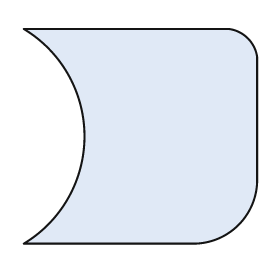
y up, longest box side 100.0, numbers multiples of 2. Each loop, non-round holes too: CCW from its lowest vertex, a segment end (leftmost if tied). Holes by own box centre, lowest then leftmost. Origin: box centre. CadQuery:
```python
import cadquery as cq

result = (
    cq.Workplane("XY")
    .moveTo(-50.0, -46.0)
    .lineTo(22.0, -46.0)
    .threePointArc((42.0, -38.0), (50.0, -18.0))
    .lineTo(50.0, 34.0)
    .threePointArc((46.0, 42.0), (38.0, 46.0))
    .lineTo(-50.0, 46.0)
    .threePointArc((-24.0, 0.0), (-50.0, -46.0))
    .close()
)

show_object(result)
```